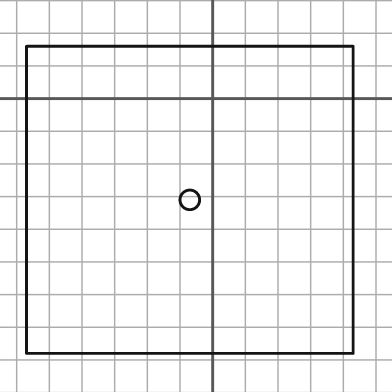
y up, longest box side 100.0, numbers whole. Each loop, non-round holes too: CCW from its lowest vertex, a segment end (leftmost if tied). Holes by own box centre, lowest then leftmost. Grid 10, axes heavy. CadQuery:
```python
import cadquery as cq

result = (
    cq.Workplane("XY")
    .moveTo(-57.0, -78.0)
    .lineTo(43.0, -78.0)
    .lineTo(43.0, 16.0)
    .lineTo(-57.0, 16.0)
    .close()
    .moveTo(-7.0, -31.0)
    .circle(3.0)
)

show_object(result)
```